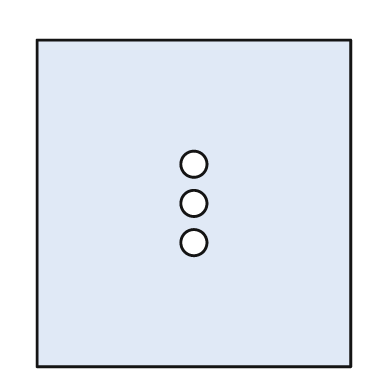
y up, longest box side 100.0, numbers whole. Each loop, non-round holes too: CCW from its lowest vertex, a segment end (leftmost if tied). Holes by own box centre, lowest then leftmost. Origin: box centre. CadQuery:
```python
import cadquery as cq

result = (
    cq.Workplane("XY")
    .moveTo(-48.0, -50.0)
    .lineTo(48.0, -50.0)
    .lineTo(48.0, 50.0)
    .lineTo(-48.0, 50.0)
    .close()
    .moveTo(0.0, -12.0)
    .circle(4.0)
    .moveTo(0.0, 0.0)
    .circle(4.0)
    .moveTo(0.0, 12.0)
    .circle(4.0)
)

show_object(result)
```